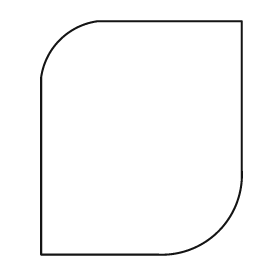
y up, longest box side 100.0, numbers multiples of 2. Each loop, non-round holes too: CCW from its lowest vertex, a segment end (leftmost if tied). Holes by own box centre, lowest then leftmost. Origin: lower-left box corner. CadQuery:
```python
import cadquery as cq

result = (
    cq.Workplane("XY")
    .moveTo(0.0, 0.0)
    .lineTo(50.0, 0.0)
    .threePointArc((76.0, 10.0), (86.0, 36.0))
    .lineTo(86.0, 100.0)
    .lineTo(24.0, 100.0)
    .threePointArc((8.0, 92.0), (0.0, 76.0))
    .close()
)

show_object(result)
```